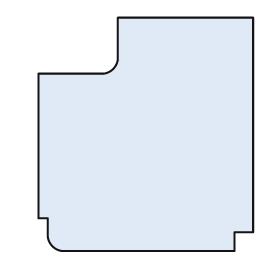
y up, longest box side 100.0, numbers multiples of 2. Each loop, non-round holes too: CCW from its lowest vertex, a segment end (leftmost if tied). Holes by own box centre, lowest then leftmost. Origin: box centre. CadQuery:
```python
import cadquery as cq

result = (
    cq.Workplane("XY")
    .moveTo(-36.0, -50.0)
    .lineTo(38.0, -50.0)
    .lineTo(38.0, -42.0)
    .lineTo(46.0, -42.0)
    .lineTo(46.0, 50.0)
    .lineTo(-12.0, 50.0)
    .lineTo(-12.0, 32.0)
    .threePointArc((-14.0, 28.0), (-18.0, 26.0))
    .lineTo(-46.0, 26.0)
    .lineTo(-46.0, -36.0)
    .lineTo(-42.0, -36.0)
    .lineTo(-42.0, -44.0)
    .threePointArc((-40.0, -48.0), (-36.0, -50.0))
    .close()
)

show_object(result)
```